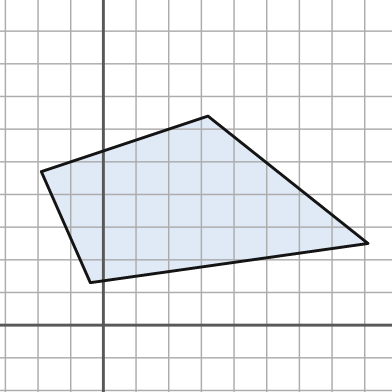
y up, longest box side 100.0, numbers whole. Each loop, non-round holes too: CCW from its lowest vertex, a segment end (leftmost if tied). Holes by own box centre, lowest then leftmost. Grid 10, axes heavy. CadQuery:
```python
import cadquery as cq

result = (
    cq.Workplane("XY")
    .moveTo(-4.0, 13.0)
    .lineTo(81.0, 25.0)
    .lineTo(32.0, 64.0)
    .lineTo(-19.0, 47.0)
    .close()
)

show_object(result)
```